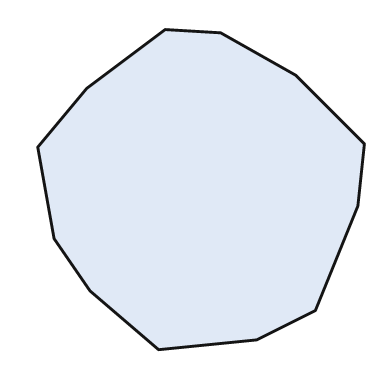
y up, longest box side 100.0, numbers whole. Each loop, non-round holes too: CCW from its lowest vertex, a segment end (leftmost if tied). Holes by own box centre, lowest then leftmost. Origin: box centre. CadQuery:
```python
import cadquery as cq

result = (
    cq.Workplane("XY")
    .moveTo(-13.0, -49.0)
    .lineTo(17.0, -46.0)
    .lineTo(35.0, -37.0)
    .lineTo(48.0, -5.0)
    .lineTo(50.0, 14.0)
    .lineTo(29.0, 35.0)
    .lineTo(6.0, 48.0)
    .lineTo(-11.0, 49.0)
    .lineTo(-35.0, 31.0)
    .lineTo(-50.0, 13.0)
    .lineTo(-45.0, -15.0)
    .lineTo(-34.0, -31.0)
    .close()
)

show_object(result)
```